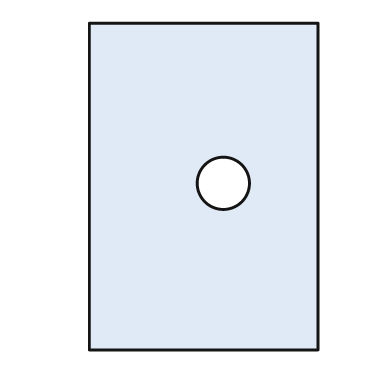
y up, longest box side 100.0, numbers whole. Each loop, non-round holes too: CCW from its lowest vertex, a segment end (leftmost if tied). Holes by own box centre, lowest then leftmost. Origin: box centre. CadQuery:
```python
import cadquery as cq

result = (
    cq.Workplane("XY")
    .moveTo(-35.0, -50.0)
    .lineTo(35.0, -50.0)
    .lineTo(35.0, 50.0)
    .lineTo(-35.0, 50.0)
    .close()
    .moveTo(6.0, 1.0)
    .circle(8.0)
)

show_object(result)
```